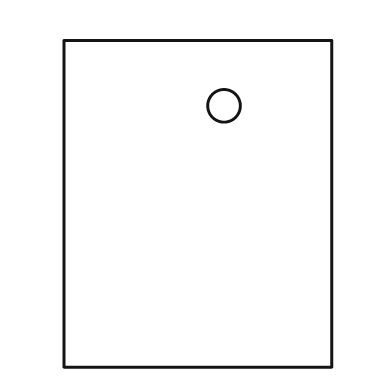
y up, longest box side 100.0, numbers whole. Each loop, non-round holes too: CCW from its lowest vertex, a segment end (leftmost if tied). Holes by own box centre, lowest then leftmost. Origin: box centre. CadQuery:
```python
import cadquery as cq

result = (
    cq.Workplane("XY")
    .moveTo(-41.0, -50.0)
    .lineTo(41.0, -50.0)
    .lineTo(41.0, 50.0)
    .lineTo(-41.0, 50.0)
    .close()
    .moveTo(8.0, 30.0)
    .circle(5.0)
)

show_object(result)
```